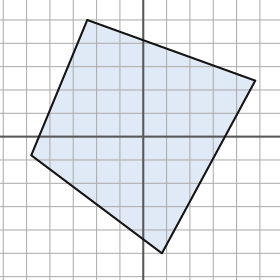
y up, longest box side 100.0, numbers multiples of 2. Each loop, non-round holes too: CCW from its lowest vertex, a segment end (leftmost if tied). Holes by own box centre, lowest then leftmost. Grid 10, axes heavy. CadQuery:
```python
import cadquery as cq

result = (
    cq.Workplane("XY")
    .moveTo(8.0, -50.0)
    .lineTo(48.0, 24.0)
    .lineTo(-24.0, 50.0)
    .lineTo(-48.0, -8.0)
    .close()
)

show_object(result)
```